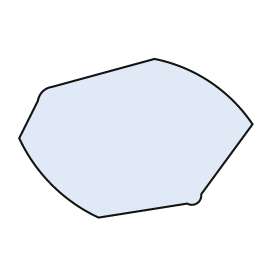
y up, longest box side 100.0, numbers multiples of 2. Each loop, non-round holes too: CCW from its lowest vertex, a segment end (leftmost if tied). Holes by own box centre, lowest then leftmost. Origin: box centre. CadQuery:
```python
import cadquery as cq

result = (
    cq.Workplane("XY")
    .moveTo(-16.0, -34.0)
    .lineTo(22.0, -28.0)
    .threePointArc((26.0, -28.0), (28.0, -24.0))
    .lineTo(50.0, 6.0)
    .threePointArc((32.0, 24.0), (8.0, 34.0))
    .lineTo(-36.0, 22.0)
    .threePointArc((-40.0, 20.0), (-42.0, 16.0))
    .lineTo(-50.0, 0.0)
    .threePointArc((-36.0, -20.0), (-16.0, -34.0))
    .close()
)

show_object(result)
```